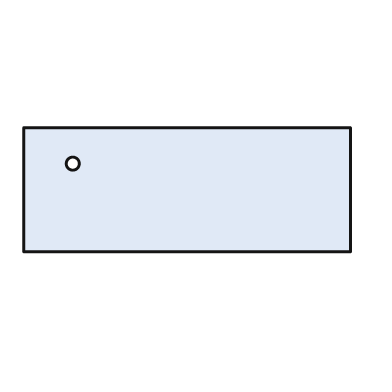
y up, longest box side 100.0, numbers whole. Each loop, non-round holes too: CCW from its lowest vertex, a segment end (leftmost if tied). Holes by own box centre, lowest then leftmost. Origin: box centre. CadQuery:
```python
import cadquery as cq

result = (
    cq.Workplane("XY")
    .moveTo(-50.0, -19.0)
    .lineTo(50.0, -19.0)
    .lineTo(50.0, 19.0)
    .lineTo(-50.0, 19.0)
    .close()
    .moveTo(-35.0, 8.0)
    .circle(2.0)
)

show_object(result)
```